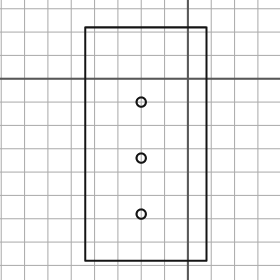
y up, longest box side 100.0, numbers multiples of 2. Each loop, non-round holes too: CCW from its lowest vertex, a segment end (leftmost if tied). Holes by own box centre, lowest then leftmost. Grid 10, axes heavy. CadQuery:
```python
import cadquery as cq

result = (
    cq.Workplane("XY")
    .moveTo(-44.0, -78.0)
    .lineTo(8.0, -78.0)
    .lineTo(8.0, 22.0)
    .lineTo(-44.0, 22.0)
    .close()
    .moveTo(-20.0, -58.0)
    .circle(2.0)
    .moveTo(-20.0, -34.0)
    .circle(2.0)
    .moveTo(-20.0, -10.0)
    .circle(2.0)
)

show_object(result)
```